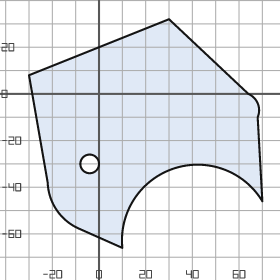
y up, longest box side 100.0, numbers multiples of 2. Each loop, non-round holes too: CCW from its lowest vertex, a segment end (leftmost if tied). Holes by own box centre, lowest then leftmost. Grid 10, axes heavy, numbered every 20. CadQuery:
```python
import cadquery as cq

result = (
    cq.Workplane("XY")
    .moveTo(10.0, -66.0)
    .threePointArc((32.0, -32.0), (70.0, -46.0))
    .lineTo(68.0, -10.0)
    .threePointArc((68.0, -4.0), (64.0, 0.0))
    .lineTo(30.0, 32.0)
    .lineTo(-30.0, 8.0)
    .lineTo(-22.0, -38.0)
    .threePointArc((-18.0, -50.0), (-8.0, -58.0))
    .close()
    .moveTo(-4.0, -30.0)
    .circle(4.0)
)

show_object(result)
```